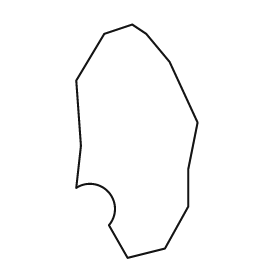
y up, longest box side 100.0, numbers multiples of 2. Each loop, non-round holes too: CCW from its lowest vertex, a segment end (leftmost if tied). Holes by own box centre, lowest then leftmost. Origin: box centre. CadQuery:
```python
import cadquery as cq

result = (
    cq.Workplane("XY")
    .moveTo(-4.0, -50.0)
    .lineTo(12.0, -46.0)
    .lineTo(22.0, -28.0)
    .lineTo(22.0, -12.0)
    .lineTo(26.0, 8.0)
    .lineTo(14.0, 34.0)
    .lineTo(4.0, 46.0)
    .lineTo(-2.0, 50.0)
    .lineTo(-14.0, 46.0)
    .lineTo(-26.0, 26.0)
    .lineTo(-24.0, -2.0)
    .lineTo(-26.0, -20.0)
    .threePointArc((-12.0, -22.0), (-12.0, -36.0))
    .close()
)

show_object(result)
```